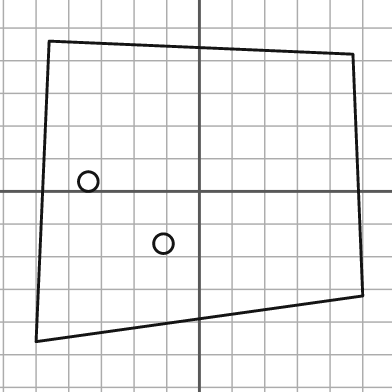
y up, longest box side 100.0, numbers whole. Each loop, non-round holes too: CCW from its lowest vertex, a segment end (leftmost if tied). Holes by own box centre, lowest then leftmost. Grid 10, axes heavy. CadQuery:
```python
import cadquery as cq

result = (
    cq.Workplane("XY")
    .moveTo(-50.0, -46.0)
    .lineTo(50.0, -32.0)
    .lineTo(47.0, 42.0)
    .lineTo(-46.0, 46.0)
    .close()
    .moveTo(-11.0, -16.0)
    .circle(3.0)
    .moveTo(-34.0, 3.0)
    .circle(3.0)
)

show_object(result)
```